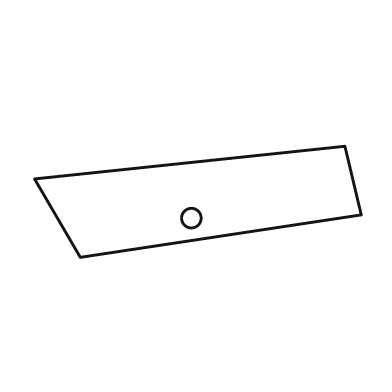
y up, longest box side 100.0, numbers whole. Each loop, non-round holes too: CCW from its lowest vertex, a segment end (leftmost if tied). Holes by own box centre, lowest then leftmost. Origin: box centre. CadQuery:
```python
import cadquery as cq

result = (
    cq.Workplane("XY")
    .moveTo(-36.0, -17.0)
    .lineTo(50.0, -4.0)
    .lineTo(45.0, 17.0)
    .lineTo(-50.0, 7.0)
    .close()
    .moveTo(-2.0, -5.0)
    .circle(3.0)
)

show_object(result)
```